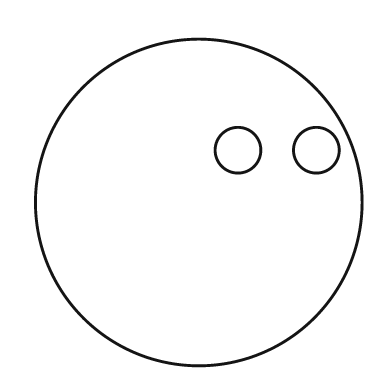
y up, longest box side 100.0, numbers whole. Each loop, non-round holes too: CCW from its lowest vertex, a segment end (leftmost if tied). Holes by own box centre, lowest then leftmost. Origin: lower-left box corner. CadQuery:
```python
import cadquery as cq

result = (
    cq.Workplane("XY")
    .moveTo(50.0, 50.0)
    .circle(50.0)
    .moveTo(62.0, 66.0)
    .circle(7.0)
    .moveTo(86.0, 66.0)
    .circle(7.0)
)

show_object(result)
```